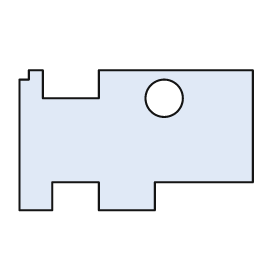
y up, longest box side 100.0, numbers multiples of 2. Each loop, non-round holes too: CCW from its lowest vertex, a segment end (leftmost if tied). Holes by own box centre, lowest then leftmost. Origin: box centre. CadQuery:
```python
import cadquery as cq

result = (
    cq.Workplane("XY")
    .moveTo(-50.0, -30.0)
    .lineTo(-36.0, -30.0)
    .lineTo(-36.0, -18.0)
    .lineTo(-16.0, -18.0)
    .lineTo(-16.0, -30.0)
    .lineTo(8.0, -30.0)
    .lineTo(8.0, -18.0)
    .lineTo(50.0, -18.0)
    .lineTo(50.0, 30.0)
    .lineTo(-16.0, 30.0)
    .lineTo(-16.0, 18.0)
    .lineTo(-40.0, 18.0)
    .lineTo(-40.0, 30.0)
    .lineTo(-46.0, 30.0)
    .lineTo(-46.0, 26.0)
    .lineTo(-50.0, 26.0)
    .close()
    .moveTo(12.0, 18.0)
    .circle(8.0)
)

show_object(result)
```